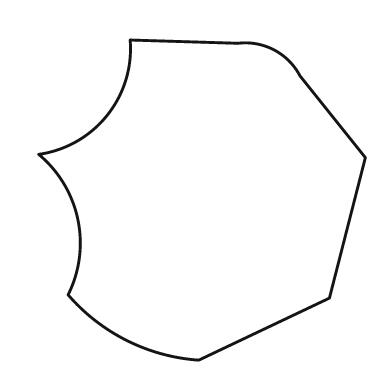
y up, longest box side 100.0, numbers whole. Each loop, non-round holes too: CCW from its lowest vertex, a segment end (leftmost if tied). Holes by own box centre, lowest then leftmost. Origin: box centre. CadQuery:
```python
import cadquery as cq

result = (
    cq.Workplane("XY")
    .moveTo(-1.0, -49.0)
    .lineTo(39.0, -30.0)
    .lineTo(50.0, 13.0)
    .lineTo(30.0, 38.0)
    .threePointArc((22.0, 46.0), (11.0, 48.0))
    .lineTo(-22.0, 49.0)
    .threePointArc((-29.0, 26.0), (-50.0, 14.0))
    .threePointArc((-38.0, -6.0), (-41.0, -29.0))
    .threePointArc((-23.0, -43.0), (-1.0, -49.0))
    .close()
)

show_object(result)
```